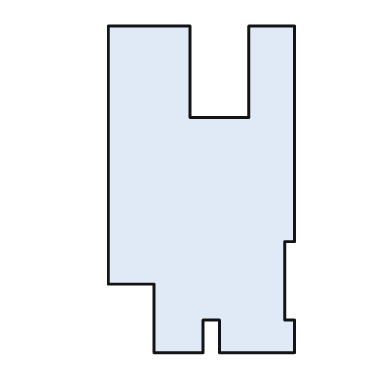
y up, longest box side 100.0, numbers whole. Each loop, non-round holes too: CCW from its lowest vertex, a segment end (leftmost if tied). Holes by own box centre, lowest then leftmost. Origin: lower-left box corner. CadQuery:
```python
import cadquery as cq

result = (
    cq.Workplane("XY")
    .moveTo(14.0, 0.0)
    .lineTo(29.0, 0.0)
    .lineTo(29.0, 10.0)
    .lineTo(34.0, 10.0)
    .lineTo(34.0, 0.0)
    .lineTo(57.0, 0.0)
    .lineTo(57.0, 10.0)
    .lineTo(54.0, 10.0)
    .lineTo(54.0, 34.0)
    .lineTo(57.0, 34.0)
    .lineTo(57.0, 100.0)
    .lineTo(43.0, 100.0)
    .lineTo(43.0, 72.0)
    .lineTo(25.0, 72.0)
    .lineTo(25.0, 100.0)
    .lineTo(0.0, 100.0)
    .lineTo(0.0, 21.0)
    .lineTo(14.0, 21.0)
    .close()
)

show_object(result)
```